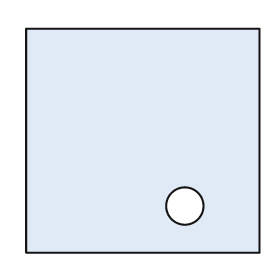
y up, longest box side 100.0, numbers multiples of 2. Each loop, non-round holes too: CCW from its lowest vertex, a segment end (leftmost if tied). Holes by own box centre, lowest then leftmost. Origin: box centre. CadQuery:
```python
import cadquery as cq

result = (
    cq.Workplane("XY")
    .moveTo(-50.0, -48.0)
    .lineTo(50.0, -48.0)
    .lineTo(50.0, 48.0)
    .lineTo(-50.0, 48.0)
    .close()
    .moveTo(18.0, -28.0)
    .circle(8.0)
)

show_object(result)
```